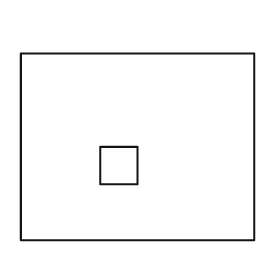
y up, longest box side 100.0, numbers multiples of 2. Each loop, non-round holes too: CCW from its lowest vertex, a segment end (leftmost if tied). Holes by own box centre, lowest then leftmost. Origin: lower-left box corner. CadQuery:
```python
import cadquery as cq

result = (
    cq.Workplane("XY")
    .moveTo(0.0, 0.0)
    .lineTo(100.0, 0.0)
    .lineTo(100.0, 80.0)
    .lineTo(0.0, 80.0)
    .close()
    .moveTo(34.0, 24.0)
    .lineTo(50.0, 24.0)
    .lineTo(50.0, 40.0)
    .lineTo(34.0, 40.0)
    .close()
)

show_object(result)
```